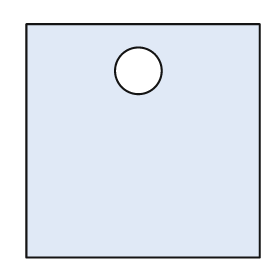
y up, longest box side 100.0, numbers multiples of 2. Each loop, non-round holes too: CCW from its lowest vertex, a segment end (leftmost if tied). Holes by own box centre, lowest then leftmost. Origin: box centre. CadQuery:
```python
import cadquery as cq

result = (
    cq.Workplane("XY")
    .moveTo(-50.0, -50.0)
    .lineTo(50.0, -50.0)
    .lineTo(50.0, 50.0)
    .lineTo(-50.0, 50.0)
    .close()
    .moveTo(-2.0, 30.0)
    .circle(10.0)
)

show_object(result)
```